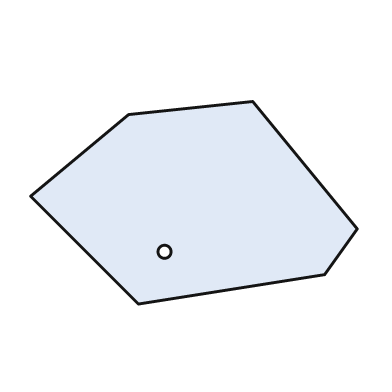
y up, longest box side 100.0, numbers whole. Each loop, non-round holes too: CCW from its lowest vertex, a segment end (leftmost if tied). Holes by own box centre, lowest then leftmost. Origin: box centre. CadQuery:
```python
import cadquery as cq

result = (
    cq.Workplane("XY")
    .moveTo(-17.0, -31.0)
    .lineTo(40.0, -22.0)
    .lineTo(50.0, -8.0)
    .lineTo(18.0, 31.0)
    .lineTo(-20.0, 27.0)
    .lineTo(-50.0, 2.0)
    .close()
    .moveTo(-9.0, -15.0)
    .circle(2.0)
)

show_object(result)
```